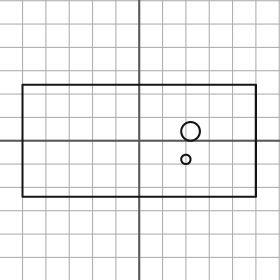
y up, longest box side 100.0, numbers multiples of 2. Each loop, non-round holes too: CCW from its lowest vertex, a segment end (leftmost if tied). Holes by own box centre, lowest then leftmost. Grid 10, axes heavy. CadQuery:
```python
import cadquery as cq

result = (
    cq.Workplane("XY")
    .moveTo(-50.0, -24.0)
    .lineTo(50.0, -24.0)
    .lineTo(50.0, 24.0)
    .lineTo(-50.0, 24.0)
    .close()
    .moveTo(20.0, -8.0)
    .circle(2.0)
    .moveTo(22.0, 4.0)
    .circle(4.0)
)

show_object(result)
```